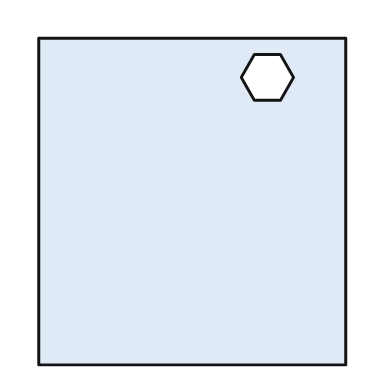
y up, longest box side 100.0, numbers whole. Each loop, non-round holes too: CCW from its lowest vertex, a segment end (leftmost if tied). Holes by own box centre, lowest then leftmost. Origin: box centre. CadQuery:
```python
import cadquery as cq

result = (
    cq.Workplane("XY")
    .moveTo(-47.0, -50.0)
    .lineTo(47.0, -50.0)
    .lineTo(47.0, 50.0)
    .lineTo(-47.0, 50.0)
    .close()
    .moveTo(19.0, 31.0)
    .lineTo(27.0, 31.0)
    .lineTo(31.0, 38.0)
    .lineTo(27.0, 45.0)
    .lineTo(19.0, 45.0)
    .lineTo(15.0, 38.0)
    .close()
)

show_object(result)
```